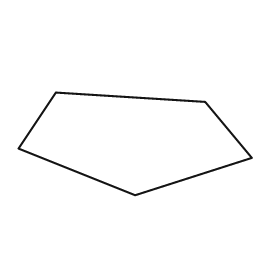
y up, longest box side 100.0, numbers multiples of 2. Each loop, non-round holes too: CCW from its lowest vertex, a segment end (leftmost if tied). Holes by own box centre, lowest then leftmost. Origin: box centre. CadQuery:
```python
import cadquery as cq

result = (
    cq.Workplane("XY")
    .moveTo(0.0, -22.0)
    .lineTo(50.0, -6.0)
    .lineTo(30.0, 18.0)
    .lineTo(-34.0, 22.0)
    .lineTo(-50.0, -2.0)
    .close()
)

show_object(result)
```